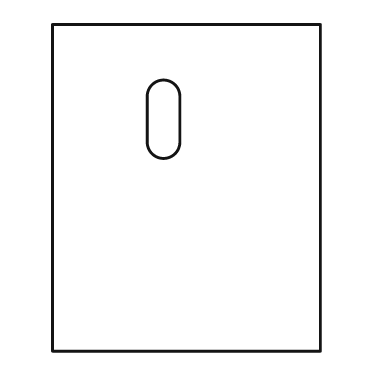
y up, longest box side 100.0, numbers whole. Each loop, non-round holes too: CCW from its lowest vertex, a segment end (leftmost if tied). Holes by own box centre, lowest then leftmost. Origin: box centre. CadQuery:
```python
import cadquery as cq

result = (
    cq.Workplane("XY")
    .moveTo(-41.0, -50.0)
    .lineTo(41.0, -50.0)
    .lineTo(41.0, 50.0)
    .lineTo(-41.0, 50.0)
    .close()
    .moveTo(-12.0, 14.0)
    .threePointArc((-7.0, 9.0), (-2.0, 14.0))
    .lineTo(-2.0, 28.0)
    .threePointArc((-7.0, 33.0), (-12.0, 28.0))
    .close()
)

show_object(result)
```